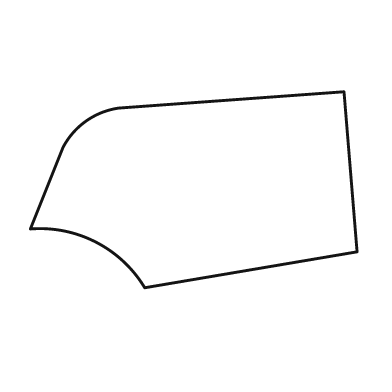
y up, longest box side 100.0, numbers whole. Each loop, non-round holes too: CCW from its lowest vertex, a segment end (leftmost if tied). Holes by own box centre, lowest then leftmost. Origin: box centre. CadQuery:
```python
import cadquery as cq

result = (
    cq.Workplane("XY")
    .moveTo(-15.0, -30.0)
    .lineTo(50.0, -19.0)
    .lineTo(46.0, 30.0)
    .lineTo(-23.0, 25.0)
    .threePointArc((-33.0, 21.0), (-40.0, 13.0))
    .lineTo(-50.0, -12.0)
    .threePointArc((-30.0, -16.0), (-15.0, -30.0))
    .close()
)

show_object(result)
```